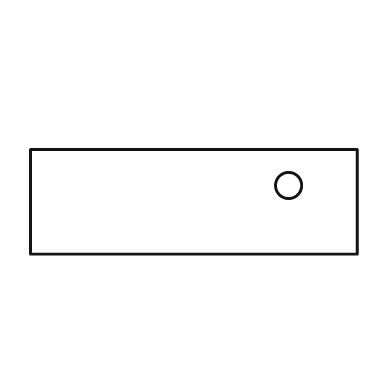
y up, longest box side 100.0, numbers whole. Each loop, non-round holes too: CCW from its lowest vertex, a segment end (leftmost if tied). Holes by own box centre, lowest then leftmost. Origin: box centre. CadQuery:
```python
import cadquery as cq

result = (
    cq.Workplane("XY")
    .moveTo(-50.0, -16.0)
    .lineTo(50.0, -16.0)
    .lineTo(50.0, 16.0)
    .lineTo(-50.0, 16.0)
    .close()
    .moveTo(29.0, 5.0)
    .circle(4.0)
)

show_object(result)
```